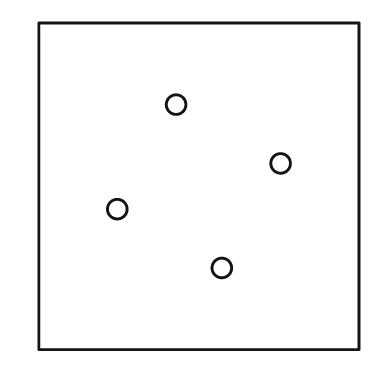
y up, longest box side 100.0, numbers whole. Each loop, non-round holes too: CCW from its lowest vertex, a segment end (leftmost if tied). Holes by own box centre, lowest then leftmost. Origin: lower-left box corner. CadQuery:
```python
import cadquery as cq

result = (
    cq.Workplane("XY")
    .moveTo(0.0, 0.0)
    .lineTo(98.0, 0.0)
    .lineTo(98.0, 100.0)
    .lineTo(0.0, 100.0)
    .close()
    .moveTo(56.0, 25.0)
    .circle(3.0)
    .moveTo(24.0, 43.0)
    .circle(3.0)
    .moveTo(74.0, 57.0)
    .circle(3.0)
    .moveTo(42.0, 75.0)
    .circle(3.0)
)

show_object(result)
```